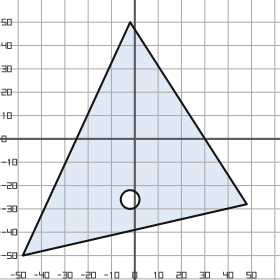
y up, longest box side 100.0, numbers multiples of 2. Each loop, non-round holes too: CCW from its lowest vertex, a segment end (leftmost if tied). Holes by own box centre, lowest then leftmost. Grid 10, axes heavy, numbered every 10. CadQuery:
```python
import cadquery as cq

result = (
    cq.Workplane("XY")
    .moveTo(-48.0, -50.0)
    .lineTo(48.0, -28.0)
    .lineTo(-2.0, 50.0)
    .close()
    .moveTo(-2.0, -26.0)
    .circle(4.0)
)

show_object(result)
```